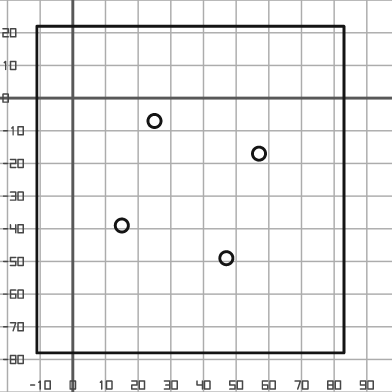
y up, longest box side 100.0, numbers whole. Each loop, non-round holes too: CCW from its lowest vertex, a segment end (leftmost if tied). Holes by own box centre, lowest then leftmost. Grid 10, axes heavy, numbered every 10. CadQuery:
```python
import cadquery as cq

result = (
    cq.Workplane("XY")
    .moveTo(-11.0, -78.0)
    .lineTo(83.0, -78.0)
    .lineTo(83.0, 22.0)
    .lineTo(-11.0, 22.0)
    .close()
    .moveTo(47.0, -49.0)
    .circle(2.0)
    .moveTo(15.0, -39.0)
    .circle(2.0)
    .moveTo(57.0, -17.0)
    .circle(2.0)
    .moveTo(25.0, -7.0)
    .circle(2.0)
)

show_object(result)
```